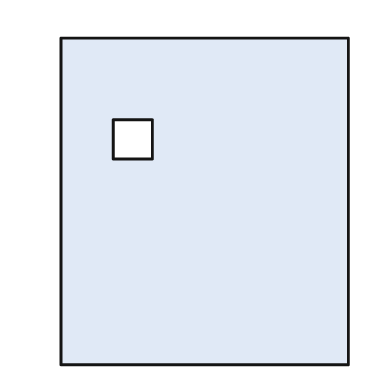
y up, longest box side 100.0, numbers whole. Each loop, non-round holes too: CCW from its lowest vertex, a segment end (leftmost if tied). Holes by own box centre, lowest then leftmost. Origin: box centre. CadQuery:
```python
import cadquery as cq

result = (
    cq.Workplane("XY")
    .moveTo(-44.0, -50.0)
    .lineTo(44.0, -50.0)
    .lineTo(44.0, 50.0)
    .lineTo(-44.0, 50.0)
    .close()
    .moveTo(-28.0, 13.0)
    .lineTo(-16.0, 13.0)
    .lineTo(-16.0, 25.0)
    .lineTo(-28.0, 25.0)
    .close()
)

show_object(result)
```